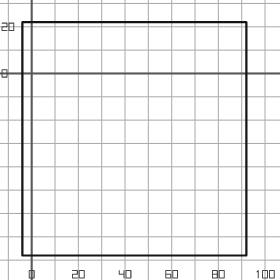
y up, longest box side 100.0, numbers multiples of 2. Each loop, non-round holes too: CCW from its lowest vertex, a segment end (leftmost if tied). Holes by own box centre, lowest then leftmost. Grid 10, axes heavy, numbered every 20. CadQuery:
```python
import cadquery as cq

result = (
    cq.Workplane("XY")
    .moveTo(-4.0, -78.0)
    .lineTo(92.0, -78.0)
    .lineTo(92.0, 22.0)
    .lineTo(-4.0, 22.0)
    .close()
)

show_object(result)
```